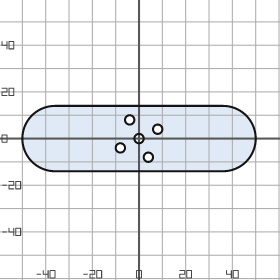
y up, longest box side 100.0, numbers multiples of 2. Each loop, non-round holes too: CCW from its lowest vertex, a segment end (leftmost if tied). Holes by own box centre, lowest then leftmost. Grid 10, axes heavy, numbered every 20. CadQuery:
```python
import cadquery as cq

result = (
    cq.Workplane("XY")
    .moveTo(-36.0, -14.0)
    .lineTo(36.0, -14.0)
    .threePointArc((50.0, 0.0), (36.0, 14.0))
    .lineTo(-36.0, 14.0)
    .threePointArc((-50.0, 0.0), (-36.0, -14.0))
    .close()
    .moveTo(4.0, -8.0)
    .circle(2.0)
    .moveTo(-8.0, -4.0)
    .circle(2.0)
    .moveTo(0.0, 0.0)
    .circle(2.0)
    .moveTo(8.0, 4.0)
    .circle(2.0)
    .moveTo(-4.0, 8.0)
    .circle(2.0)
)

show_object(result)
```